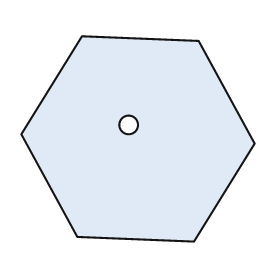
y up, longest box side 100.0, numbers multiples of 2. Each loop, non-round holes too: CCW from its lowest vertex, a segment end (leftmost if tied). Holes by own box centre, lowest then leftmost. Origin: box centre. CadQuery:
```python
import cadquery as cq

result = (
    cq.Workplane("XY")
    .moveTo(24.0, -44.0)
    .lineTo(50.0, -2.0)
    .lineTo(26.0, 42.0)
    .lineTo(-24.0, 44.0)
    .lineTo(-50.0, 2.0)
    .lineTo(-26.0, -42.0)
    .close()
    .moveTo(-4.0, 6.0)
    .circle(4.0)
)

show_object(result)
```